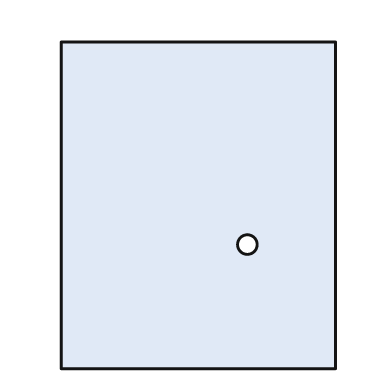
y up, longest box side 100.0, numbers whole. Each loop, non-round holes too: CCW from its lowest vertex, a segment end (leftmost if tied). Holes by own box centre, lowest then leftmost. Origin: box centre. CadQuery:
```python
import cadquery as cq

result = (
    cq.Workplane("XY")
    .moveTo(-42.0, -50.0)
    .lineTo(42.0, -50.0)
    .lineTo(42.0, 50.0)
    .lineTo(-42.0, 50.0)
    .close()
    .moveTo(15.0, -12.0)
    .circle(3.0)
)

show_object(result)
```